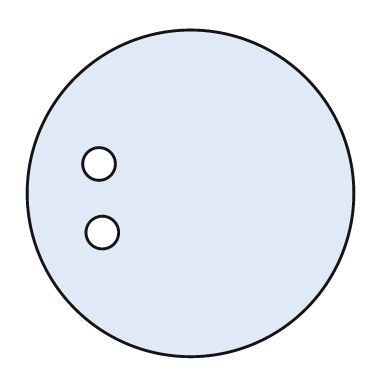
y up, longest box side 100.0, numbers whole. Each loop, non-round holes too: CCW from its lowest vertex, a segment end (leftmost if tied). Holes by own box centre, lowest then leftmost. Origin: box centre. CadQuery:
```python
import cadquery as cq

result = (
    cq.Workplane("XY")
    .moveTo(0.0, 0.0)
    .circle(50.0)
    .moveTo(-27.0, -12.0)
    .circle(5.0)
    .moveTo(-28.0, 9.0)
    .circle(5.0)
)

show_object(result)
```